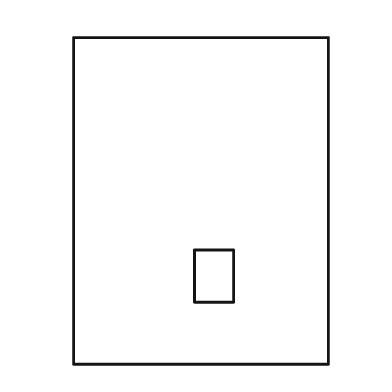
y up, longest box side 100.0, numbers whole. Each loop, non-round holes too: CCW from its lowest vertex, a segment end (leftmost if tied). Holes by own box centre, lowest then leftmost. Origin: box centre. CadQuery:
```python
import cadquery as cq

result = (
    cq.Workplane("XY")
    .moveTo(-39.0, -50.0)
    .lineTo(39.0, -50.0)
    .lineTo(39.0, 50.0)
    .lineTo(-39.0, 50.0)
    .close()
    .moveTo(-2.0, -31.0)
    .lineTo(10.0, -31.0)
    .lineTo(10.0, -15.0)
    .lineTo(-2.0, -15.0)
    .close()
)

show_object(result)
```